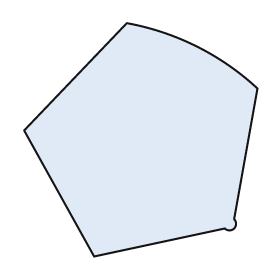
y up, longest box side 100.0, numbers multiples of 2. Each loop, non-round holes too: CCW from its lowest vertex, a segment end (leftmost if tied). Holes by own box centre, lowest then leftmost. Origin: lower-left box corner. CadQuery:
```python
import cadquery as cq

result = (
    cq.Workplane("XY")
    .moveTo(30.0, 0.0)
    .lineTo(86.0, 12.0)
    .threePointArc((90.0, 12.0), (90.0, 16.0))
    .lineTo(100.0, 72.0)
    .threePointArc((74.0, 90.0), (44.0, 100.0))
    .lineTo(0.0, 54.0)
    .close()
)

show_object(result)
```